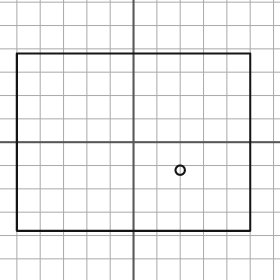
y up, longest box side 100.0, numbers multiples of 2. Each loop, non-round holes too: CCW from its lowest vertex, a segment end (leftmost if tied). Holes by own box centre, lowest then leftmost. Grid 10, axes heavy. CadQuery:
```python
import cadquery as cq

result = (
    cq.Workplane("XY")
    .moveTo(-50.0, -38.0)
    .lineTo(50.0, -38.0)
    .lineTo(50.0, 38.0)
    .lineTo(-50.0, 38.0)
    .close()
    .moveTo(20.0, -12.0)
    .circle(2.0)
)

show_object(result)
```